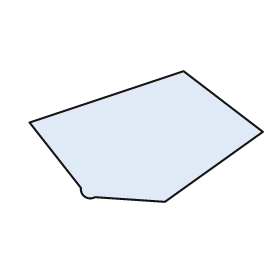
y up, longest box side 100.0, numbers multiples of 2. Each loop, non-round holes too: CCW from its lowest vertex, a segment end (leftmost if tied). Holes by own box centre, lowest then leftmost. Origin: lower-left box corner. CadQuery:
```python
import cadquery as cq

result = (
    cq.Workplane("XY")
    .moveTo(58.0, 0.0)
    .lineTo(100.0, 30.0)
    .lineTo(66.0, 56.0)
    .lineTo(0.0, 34.0)
    .lineTo(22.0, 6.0)
    .threePointArc((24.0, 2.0), (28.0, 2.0))
    .close()
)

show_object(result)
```